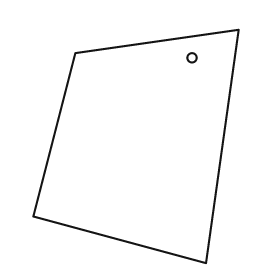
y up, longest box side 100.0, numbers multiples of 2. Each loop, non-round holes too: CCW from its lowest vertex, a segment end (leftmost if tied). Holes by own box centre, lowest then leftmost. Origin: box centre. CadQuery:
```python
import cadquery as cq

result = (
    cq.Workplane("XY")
    .moveTo(30.0, -50.0)
    .lineTo(44.0, 50.0)
    .lineTo(-26.0, 40.0)
    .lineTo(-44.0, -30.0)
    .close()
    .moveTo(24.0, 38.0)
    .circle(2.0)
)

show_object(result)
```